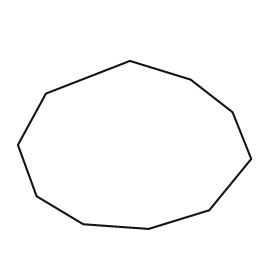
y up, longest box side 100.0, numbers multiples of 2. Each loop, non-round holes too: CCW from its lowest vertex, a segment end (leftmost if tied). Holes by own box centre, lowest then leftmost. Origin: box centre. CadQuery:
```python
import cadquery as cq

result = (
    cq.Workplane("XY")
    .moveTo(6.0, -36.0)
    .lineTo(32.0, -28.0)
    .lineTo(50.0, -6.0)
    .lineTo(42.0, 14.0)
    .lineTo(24.0, 28.0)
    .lineTo(-2.0, 36.0)
    .lineTo(-38.0, 22.0)
    .lineTo(-50.0, 0.0)
    .lineTo(-42.0, -22.0)
    .lineTo(-22.0, -34.0)
    .close()
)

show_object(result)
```